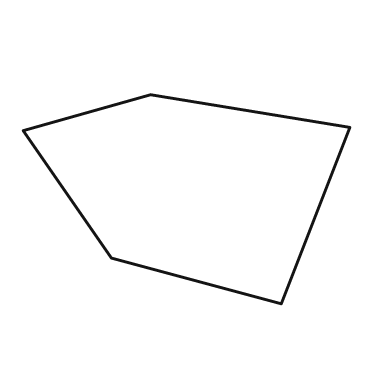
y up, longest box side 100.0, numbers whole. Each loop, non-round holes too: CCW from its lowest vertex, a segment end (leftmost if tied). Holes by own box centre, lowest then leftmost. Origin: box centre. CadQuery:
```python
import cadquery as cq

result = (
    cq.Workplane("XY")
    .moveTo(29.0, -32.0)
    .lineTo(50.0, 22.0)
    .lineTo(-11.0, 32.0)
    .lineTo(-50.0, 21.0)
    .lineTo(-23.0, -18.0)
    .close()
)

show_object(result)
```